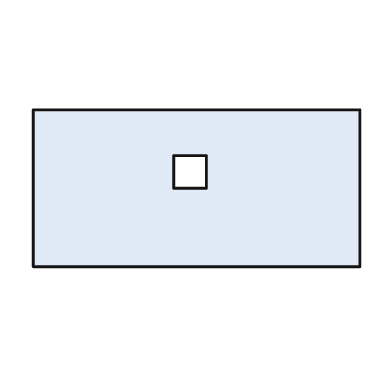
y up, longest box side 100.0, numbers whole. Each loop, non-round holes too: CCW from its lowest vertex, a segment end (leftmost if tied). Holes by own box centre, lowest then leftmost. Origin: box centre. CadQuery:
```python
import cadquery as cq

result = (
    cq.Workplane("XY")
    .moveTo(-50.0, -24.0)
    .lineTo(50.0, -24.0)
    .lineTo(50.0, 24.0)
    .lineTo(-50.0, 24.0)
    .close()
    .moveTo(-7.0, 0.0)
    .lineTo(3.0, 0.0)
    .lineTo(3.0, 10.0)
    .lineTo(-7.0, 10.0)
    .close()
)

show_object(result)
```